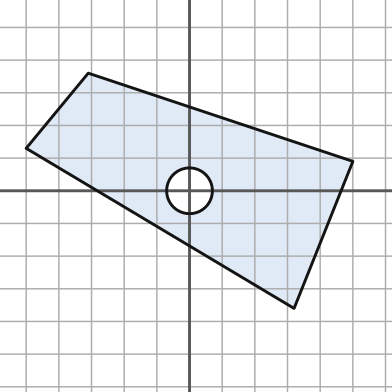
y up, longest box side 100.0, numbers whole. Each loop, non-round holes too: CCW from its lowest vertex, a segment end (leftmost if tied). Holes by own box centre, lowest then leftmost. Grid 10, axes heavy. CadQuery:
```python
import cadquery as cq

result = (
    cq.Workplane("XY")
    .moveTo(32.0, -36.0)
    .lineTo(50.0, 9.0)
    .lineTo(-31.0, 36.0)
    .lineTo(-50.0, 13.0)
    .close()
    .moveTo(0.0, 0.0)
    .circle(7.0)
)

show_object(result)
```